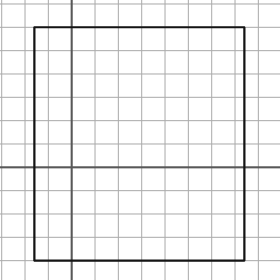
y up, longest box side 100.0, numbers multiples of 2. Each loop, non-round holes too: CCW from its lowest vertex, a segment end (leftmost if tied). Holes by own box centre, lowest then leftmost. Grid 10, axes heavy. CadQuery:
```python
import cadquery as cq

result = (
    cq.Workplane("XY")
    .moveTo(-16.0, -40.0)
    .lineTo(74.0, -40.0)
    .lineTo(74.0, 60.0)
    .lineTo(-16.0, 60.0)
    .close()
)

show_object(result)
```